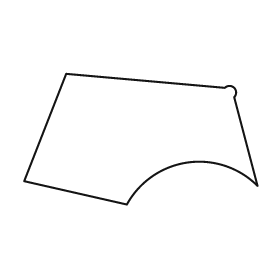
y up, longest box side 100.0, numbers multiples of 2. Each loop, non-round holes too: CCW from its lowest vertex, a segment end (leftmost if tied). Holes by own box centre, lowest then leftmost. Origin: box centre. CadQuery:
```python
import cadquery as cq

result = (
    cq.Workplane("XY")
    .moveTo(-6.0, -28.0)
    .threePointArc((20.0, -10.0), (50.0, -20.0))
    .lineTo(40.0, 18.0)
    .threePointArc((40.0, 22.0), (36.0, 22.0))
    .lineTo(-32.0, 28.0)
    .lineTo(-50.0, -18.0)
    .close()
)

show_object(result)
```